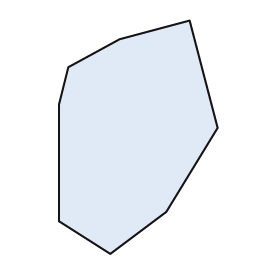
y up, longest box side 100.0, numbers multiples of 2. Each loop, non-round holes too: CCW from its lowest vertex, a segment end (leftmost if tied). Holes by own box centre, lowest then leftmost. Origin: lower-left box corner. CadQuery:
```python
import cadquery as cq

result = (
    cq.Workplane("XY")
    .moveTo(22.0, 0.0)
    .lineTo(46.0, 18.0)
    .lineTo(68.0, 54.0)
    .lineTo(56.0, 100.0)
    .lineTo(26.0, 92.0)
    .lineTo(4.0, 80.0)
    .lineTo(0.0, 64.0)
    .lineTo(0.0, 14.0)
    .close()
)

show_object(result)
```